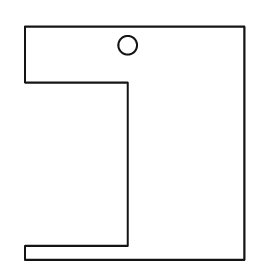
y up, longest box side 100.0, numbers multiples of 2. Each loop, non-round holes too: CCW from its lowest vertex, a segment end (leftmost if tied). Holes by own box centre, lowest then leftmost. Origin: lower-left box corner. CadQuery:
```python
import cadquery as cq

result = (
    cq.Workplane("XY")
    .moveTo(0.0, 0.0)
    .lineTo(94.0, 0.0)
    .lineTo(94.0, 100.0)
    .lineTo(0.0, 100.0)
    .lineTo(0.0, 76.0)
    .lineTo(44.0, 76.0)
    .lineTo(44.0, 6.0)
    .lineTo(0.0, 6.0)
    .close()
    .moveTo(44.0, 92.0)
    .circle(4.0)
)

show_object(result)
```